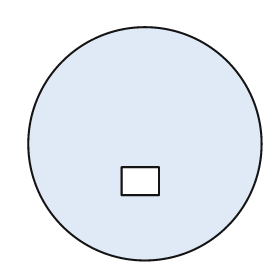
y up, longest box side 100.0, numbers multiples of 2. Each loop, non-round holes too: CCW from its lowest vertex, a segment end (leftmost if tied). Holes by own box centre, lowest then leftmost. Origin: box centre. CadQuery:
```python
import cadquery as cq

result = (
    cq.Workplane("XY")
    .moveTo(0.0, 0.0)
    .circle(50.0)
    .moveTo(-10.0, -22.0)
    .lineTo(6.0, -22.0)
    .lineTo(6.0, -10.0)
    .lineTo(-10.0, -10.0)
    .close()
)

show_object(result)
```